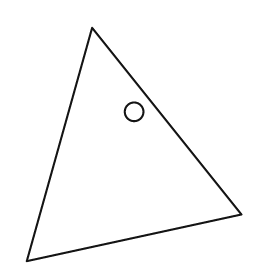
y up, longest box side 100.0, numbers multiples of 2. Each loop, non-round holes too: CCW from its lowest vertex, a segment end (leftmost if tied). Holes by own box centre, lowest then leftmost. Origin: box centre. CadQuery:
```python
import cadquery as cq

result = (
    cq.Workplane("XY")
    .moveTo(-46.0, -50.0)
    .lineTo(46.0, -30.0)
    .lineTo(-18.0, 50.0)
    .close()
    .moveTo(0.0, 14.0)
    .circle(4.0)
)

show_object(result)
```